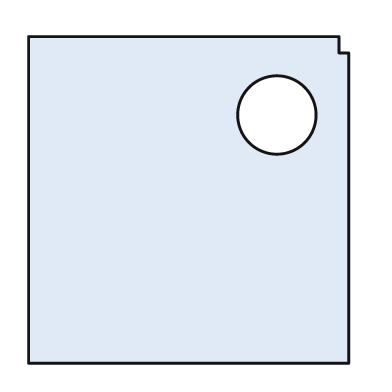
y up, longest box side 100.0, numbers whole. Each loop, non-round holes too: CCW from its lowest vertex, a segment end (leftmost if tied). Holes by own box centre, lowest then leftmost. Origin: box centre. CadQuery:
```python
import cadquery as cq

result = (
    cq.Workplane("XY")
    .moveTo(-49.0, -50.0)
    .lineTo(49.0, -50.0)
    .lineTo(49.0, 45.0)
    .lineTo(46.0, 45.0)
    .lineTo(46.0, 50.0)
    .lineTo(-49.0, 50.0)
    .close()
    .moveTo(27.0, 26.0)
    .circle(12.0)
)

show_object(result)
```